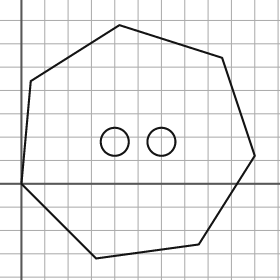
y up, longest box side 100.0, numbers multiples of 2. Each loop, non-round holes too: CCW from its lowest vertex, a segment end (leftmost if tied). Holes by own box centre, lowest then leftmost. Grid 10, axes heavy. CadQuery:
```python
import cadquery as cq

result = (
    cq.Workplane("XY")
    .moveTo(32.0, -32.0)
    .lineTo(76.0, -26.0)
    .lineTo(100.0, 12.0)
    .lineTo(86.0, 54.0)
    .lineTo(42.0, 68.0)
    .lineTo(4.0, 44.0)
    .lineTo(0.0, 0.0)
    .close()
    .moveTo(40.0, 18.0)
    .circle(6.0)
    .moveTo(60.0, 18.0)
    .circle(6.0)
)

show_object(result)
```